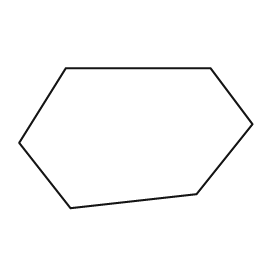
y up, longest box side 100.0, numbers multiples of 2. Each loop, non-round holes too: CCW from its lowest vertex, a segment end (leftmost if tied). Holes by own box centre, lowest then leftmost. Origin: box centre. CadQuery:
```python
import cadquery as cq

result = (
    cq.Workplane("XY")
    .moveTo(-28.0, -30.0)
    .lineTo(26.0, -24.0)
    .lineTo(50.0, 6.0)
    .lineTo(32.0, 30.0)
    .lineTo(-30.0, 30.0)
    .lineTo(-50.0, -2.0)
    .close()
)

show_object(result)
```